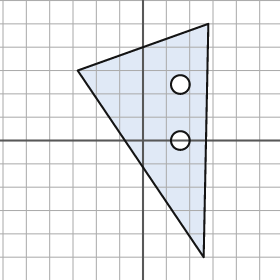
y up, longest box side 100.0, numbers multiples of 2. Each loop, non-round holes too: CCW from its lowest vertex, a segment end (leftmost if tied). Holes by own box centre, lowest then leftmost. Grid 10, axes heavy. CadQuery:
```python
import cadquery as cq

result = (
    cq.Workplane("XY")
    .moveTo(26.0, -50.0)
    .lineTo(28.0, 50.0)
    .lineTo(-28.0, 30.0)
    .close()
    .moveTo(16.0, 0.0)
    .circle(4.0)
    .moveTo(16.0, 24.0)
    .circle(4.0)
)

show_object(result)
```